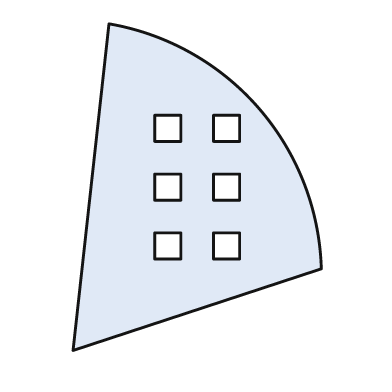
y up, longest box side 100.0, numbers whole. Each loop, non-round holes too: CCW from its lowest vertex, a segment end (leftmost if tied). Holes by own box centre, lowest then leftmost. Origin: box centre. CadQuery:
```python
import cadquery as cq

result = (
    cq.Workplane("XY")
    .moveTo(-38.0, -50.0)
    .lineTo(38.0, -25.0)
    .threePointArc((19.0, 24.0), (-27.0, 50.0))
    .close()
    .moveTo(-13.0, -22.0)
    .lineTo(-5.0, -22.0)
    .lineTo(-5.0, -14.0)
    .lineTo(-13.0, -14.0)
    .close()
    .moveTo(5.0, -22.0)
    .lineTo(13.0, -22.0)
    .lineTo(13.0, -14.0)
    .lineTo(5.0, -14.0)
    .close()
    .moveTo(-13.0, -4.0)
    .lineTo(-5.0, -4.0)
    .lineTo(-5.0, 4.0)
    .lineTo(-13.0, 4.0)
    .close()
    .moveTo(5.0, -4.0)
    .lineTo(13.0, -4.0)
    .lineTo(13.0, 4.0)
    .lineTo(5.0, 4.0)
    .close()
    .moveTo(-13.0, 14.0)
    .lineTo(-5.0, 14.0)
    .lineTo(-5.0, 22.0)
    .lineTo(-13.0, 22.0)
    .close()
    .moveTo(5.0, 14.0)
    .lineTo(13.0, 14.0)
    .lineTo(13.0, 22.0)
    .lineTo(5.0, 22.0)
    .close()
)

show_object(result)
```